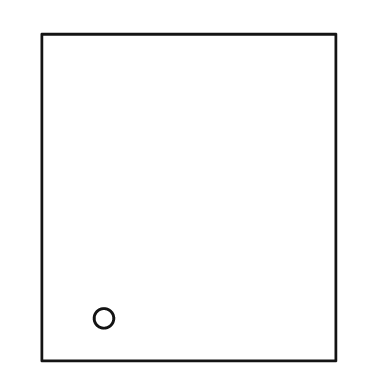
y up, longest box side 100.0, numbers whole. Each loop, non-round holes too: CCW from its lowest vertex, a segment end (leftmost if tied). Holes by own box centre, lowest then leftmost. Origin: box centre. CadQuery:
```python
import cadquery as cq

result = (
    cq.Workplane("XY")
    .moveTo(-45.0, -50.0)
    .lineTo(45.0, -50.0)
    .lineTo(45.0, 50.0)
    .lineTo(-45.0, 50.0)
    .close()
    .moveTo(-26.0, -37.0)
    .circle(3.0)
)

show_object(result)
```